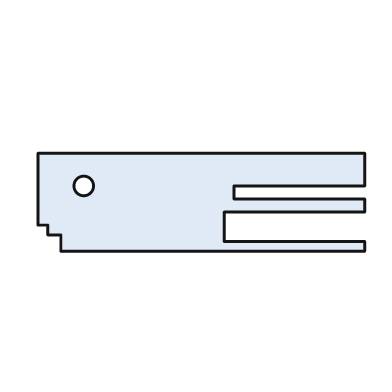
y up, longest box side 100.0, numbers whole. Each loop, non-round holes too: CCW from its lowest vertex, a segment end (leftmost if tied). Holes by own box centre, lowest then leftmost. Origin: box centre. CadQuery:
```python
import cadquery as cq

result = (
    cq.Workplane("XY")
    .moveTo(-43.0, -15.0)
    .lineTo(50.0, -15.0)
    .lineTo(50.0, -12.0)
    .lineTo(7.0, -12.0)
    .lineTo(7.0, -3.0)
    .lineTo(50.0, -3.0)
    .lineTo(50.0, 1.0)
    .lineTo(10.0, 1.0)
    .lineTo(10.0, 5.0)
    .lineTo(50.0, 5.0)
    .lineTo(50.0, 15.0)
    .lineTo(-50.0, 15.0)
    .lineTo(-50.0, -7.0)
    .lineTo(-47.0, -7.0)
    .lineTo(-47.0, -10.0)
    .lineTo(-43.0, -10.0)
    .close()
    .moveTo(-36.0, 5.0)
    .circle(3.0)
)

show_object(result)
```